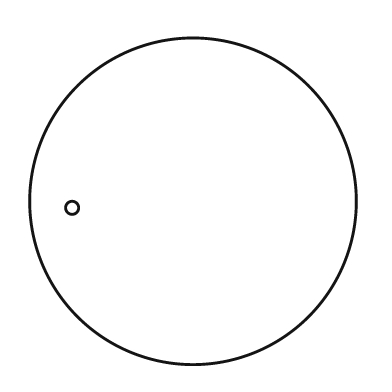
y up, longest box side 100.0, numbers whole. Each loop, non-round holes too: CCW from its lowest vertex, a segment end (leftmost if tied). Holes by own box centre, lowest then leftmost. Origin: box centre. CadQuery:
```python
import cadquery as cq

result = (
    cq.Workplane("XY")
    .moveTo(0.0, 0.0)
    .circle(50.0)
    .moveTo(-37.0, -2.0)
    .circle(2.0)
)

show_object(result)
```